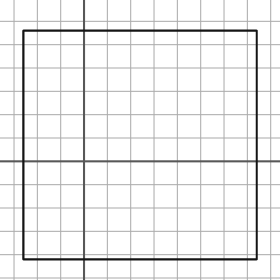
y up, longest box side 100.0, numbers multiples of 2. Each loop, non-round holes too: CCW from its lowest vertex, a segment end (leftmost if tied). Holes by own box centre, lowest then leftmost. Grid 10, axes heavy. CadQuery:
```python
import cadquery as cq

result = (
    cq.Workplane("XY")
    .moveTo(-26.0, -42.0)
    .lineTo(74.0, -42.0)
    .lineTo(74.0, 56.0)
    .lineTo(-26.0, 56.0)
    .close()
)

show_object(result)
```